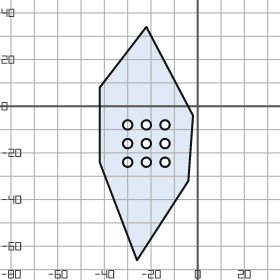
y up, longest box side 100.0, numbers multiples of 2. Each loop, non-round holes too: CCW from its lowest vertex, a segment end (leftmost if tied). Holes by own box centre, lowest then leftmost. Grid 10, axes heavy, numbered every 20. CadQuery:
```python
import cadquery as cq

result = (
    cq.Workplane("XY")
    .moveTo(-26.0, -66.0)
    .lineTo(-4.0, -32.0)
    .lineTo(-2.0, -4.0)
    .lineTo(-22.0, 34.0)
    .lineTo(-42.0, 8.0)
    .lineTo(-42.0, -24.0)
    .close()
    .moveTo(-30.0, -24.0)
    .circle(2.0)
    .moveTo(-22.0, -24.0)
    .circle(2.0)
    .moveTo(-14.0, -24.0)
    .circle(2.0)
    .moveTo(-30.0, -16.0)
    .circle(2.0)
    .moveTo(-22.0, -16.0)
    .circle(2.0)
    .moveTo(-14.0, -16.0)
    .circle(2.0)
    .moveTo(-30.0, -8.0)
    .circle(2.0)
    .moveTo(-22.0, -8.0)
    .circle(2.0)
    .moveTo(-14.0, -8.0)
    .circle(2.0)
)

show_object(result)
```